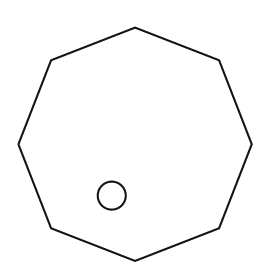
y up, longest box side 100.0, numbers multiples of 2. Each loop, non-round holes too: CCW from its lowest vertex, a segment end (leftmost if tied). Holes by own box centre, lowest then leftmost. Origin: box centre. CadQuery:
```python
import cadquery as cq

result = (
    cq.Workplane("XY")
    .moveTo(0.0, -50.0)
    .lineTo(36.0, -36.0)
    .lineTo(50.0, 0.0)
    .lineTo(36.0, 36.0)
    .lineTo(0.0, 50.0)
    .lineTo(-36.0, 36.0)
    .lineTo(-50.0, 0.0)
    .lineTo(-36.0, -36.0)
    .close()
    .moveTo(-10.0, -22.0)
    .circle(6.0)
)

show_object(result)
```